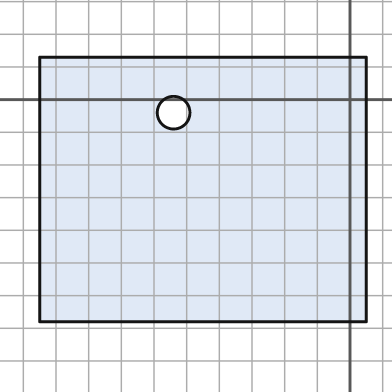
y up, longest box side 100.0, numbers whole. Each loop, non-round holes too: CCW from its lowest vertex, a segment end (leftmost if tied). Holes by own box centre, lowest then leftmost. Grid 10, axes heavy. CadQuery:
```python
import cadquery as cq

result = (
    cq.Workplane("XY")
    .moveTo(-95.0, -68.0)
    .lineTo(5.0, -68.0)
    .lineTo(5.0, 13.0)
    .lineTo(-95.0, 13.0)
    .close()
    .moveTo(-54.0, -4.0)
    .circle(5.0)
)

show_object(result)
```